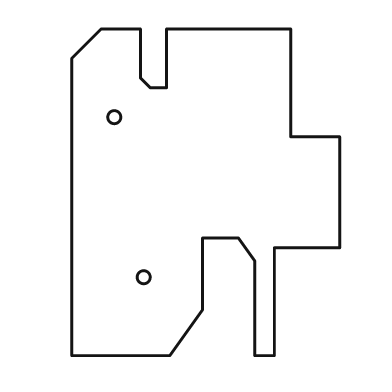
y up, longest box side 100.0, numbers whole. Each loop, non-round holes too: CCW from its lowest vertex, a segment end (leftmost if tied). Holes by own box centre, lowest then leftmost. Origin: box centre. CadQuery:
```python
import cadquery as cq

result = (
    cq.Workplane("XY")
    .moveTo(-41.0, -50.0)
    .lineTo(-11.0, -50.0)
    .lineTo(-1.0, -36.0)
    .lineTo(-1.0, -14.0)
    .lineTo(10.0, -14.0)
    .lineTo(15.0, -21.0)
    .lineTo(15.0, -50.0)
    .lineTo(21.0, -50.0)
    .lineTo(21.0, -17.0)
    .lineTo(41.0, -17.0)
    .lineTo(41.0, 17.0)
    .lineTo(26.0, 17.0)
    .lineTo(26.0, 50.0)
    .lineTo(-12.0, 50.0)
    .lineTo(-12.0, 32.0)
    .lineTo(-17.0, 32.0)
    .lineTo(-20.0, 35.0)
    .lineTo(-20.0, 50.0)
    .lineTo(-32.0, 50.0)
    .lineTo(-41.0, 41.0)
    .close()
    .moveTo(-19.0, -26.0)
    .circle(2.0)
    .moveTo(-28.0, 23.0)
    .circle(2.0)
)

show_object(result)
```